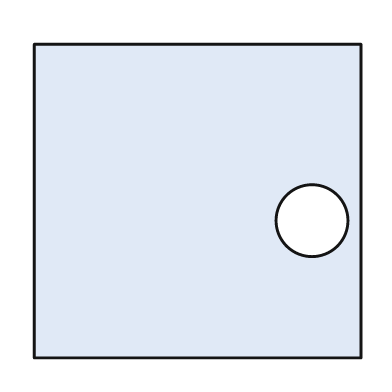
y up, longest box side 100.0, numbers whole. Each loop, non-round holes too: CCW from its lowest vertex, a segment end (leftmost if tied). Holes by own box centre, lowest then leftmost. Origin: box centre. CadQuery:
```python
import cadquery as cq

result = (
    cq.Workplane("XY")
    .moveTo(-50.0, -48.0)
    .lineTo(50.0, -48.0)
    .lineTo(50.0, 48.0)
    .lineTo(-50.0, 48.0)
    .close()
    .moveTo(35.0, -6.0)
    .circle(11.0)
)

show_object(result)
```